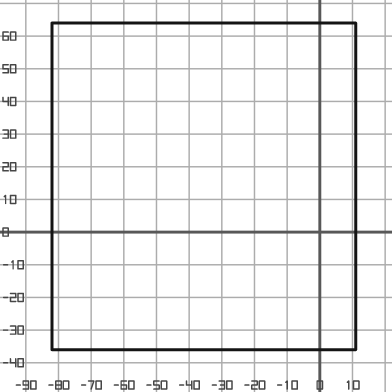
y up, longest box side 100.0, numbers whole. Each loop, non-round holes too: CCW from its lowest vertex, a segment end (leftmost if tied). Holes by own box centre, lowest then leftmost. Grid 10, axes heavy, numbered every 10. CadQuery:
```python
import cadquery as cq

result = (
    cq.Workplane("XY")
    .moveTo(-82.0, -36.0)
    .lineTo(11.0, -36.0)
    .lineTo(11.0, 64.0)
    .lineTo(-82.0, 64.0)
    .close()
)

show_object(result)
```